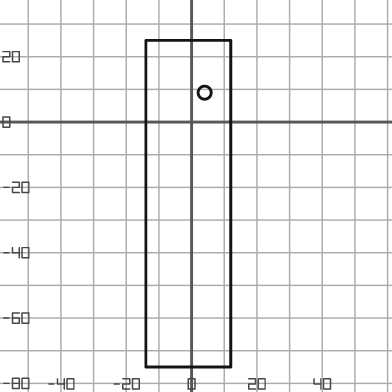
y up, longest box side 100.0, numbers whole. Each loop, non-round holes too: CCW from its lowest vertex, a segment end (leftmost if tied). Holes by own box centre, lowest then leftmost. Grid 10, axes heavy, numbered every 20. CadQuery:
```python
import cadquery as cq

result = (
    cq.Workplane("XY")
    .moveTo(-14.0, -75.0)
    .lineTo(12.0, -75.0)
    .lineTo(12.0, 25.0)
    .lineTo(-14.0, 25.0)
    .close()
    .moveTo(4.0, 9.0)
    .circle(2.0)
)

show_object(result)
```